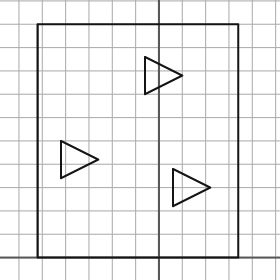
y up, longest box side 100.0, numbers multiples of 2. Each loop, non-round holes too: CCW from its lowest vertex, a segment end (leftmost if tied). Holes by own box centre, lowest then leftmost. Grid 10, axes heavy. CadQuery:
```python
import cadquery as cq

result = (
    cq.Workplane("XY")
    .moveTo(-52.0, 0.0)
    .lineTo(34.0, 0.0)
    .lineTo(34.0, 100.0)
    .lineTo(-52.0, 100.0)
    .close()
    .moveTo(6.0, 22.0)
    .lineTo(22.0, 30.0)
    .lineTo(6.0, 38.0)
    .close()
    .moveTo(-42.0, 34.0)
    .lineTo(-26.0, 42.0)
    .lineTo(-42.0, 50.0)
    .close()
    .moveTo(-6.0, 70.0)
    .lineTo(10.0, 78.0)
    .lineTo(-6.0, 86.0)
    .close()
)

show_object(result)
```